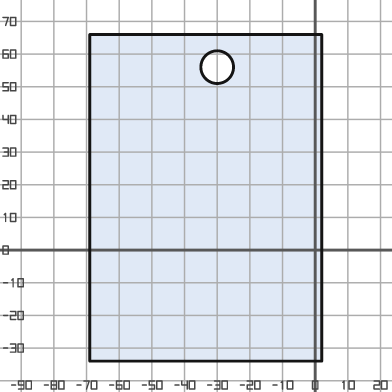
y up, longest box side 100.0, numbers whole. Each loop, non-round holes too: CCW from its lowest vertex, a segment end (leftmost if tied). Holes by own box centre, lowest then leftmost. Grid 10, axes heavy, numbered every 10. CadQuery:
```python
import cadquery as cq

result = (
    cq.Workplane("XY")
    .moveTo(-69.0, -34.0)
    .lineTo(2.0, -34.0)
    .lineTo(2.0, 66.0)
    .lineTo(-69.0, 66.0)
    .close()
    .moveTo(-30.0, 56.0)
    .circle(5.0)
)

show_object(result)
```